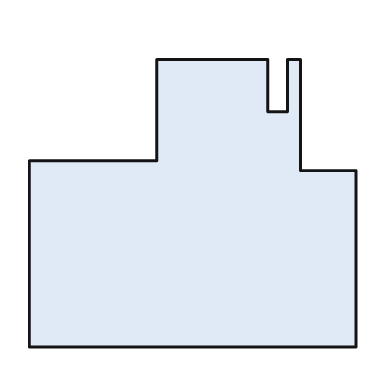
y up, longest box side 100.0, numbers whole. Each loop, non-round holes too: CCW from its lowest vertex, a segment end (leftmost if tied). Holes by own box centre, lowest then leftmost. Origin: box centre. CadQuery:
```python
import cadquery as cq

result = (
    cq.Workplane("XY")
    .moveTo(-50.0, -44.0)
    .lineTo(50.0, -44.0)
    .lineTo(50.0, 10.0)
    .lineTo(33.0, 10.0)
    .lineTo(33.0, 44.0)
    .lineTo(29.0, 44.0)
    .lineTo(29.0, 28.0)
    .lineTo(23.0, 28.0)
    .lineTo(23.0, 44.0)
    .lineTo(-11.0, 44.0)
    .lineTo(-11.0, 13.0)
    .lineTo(-50.0, 13.0)
    .close()
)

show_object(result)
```